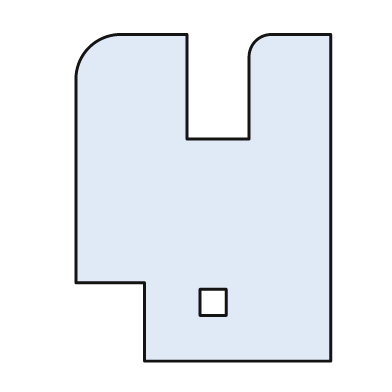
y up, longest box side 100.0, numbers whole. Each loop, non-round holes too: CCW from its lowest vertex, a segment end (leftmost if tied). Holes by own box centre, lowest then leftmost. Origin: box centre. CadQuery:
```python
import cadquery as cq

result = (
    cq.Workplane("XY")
    .moveTo(-18.0, -50.0)
    .lineTo(39.0, -50.0)
    .lineTo(39.0, 50.0)
    .lineTo(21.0, 50.0)
    .threePointArc((16.0, 48.0), (14.0, 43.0))
    .lineTo(14.0, 18.0)
    .lineTo(-5.0, 18.0)
    .lineTo(-5.0, 50.0)
    .lineTo(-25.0, 50.0)
    .threePointArc((-35.0, 46.0), (-39.0, 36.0))
    .lineTo(-39.0, -26.0)
    .lineTo(-18.0, -26.0)
    .close()
    .moveTo(-1.0, -36.0)
    .lineTo(7.0, -36.0)
    .lineTo(7.0, -28.0)
    .lineTo(-1.0, -28.0)
    .close()
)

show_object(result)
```